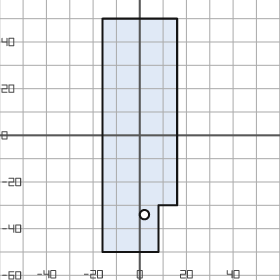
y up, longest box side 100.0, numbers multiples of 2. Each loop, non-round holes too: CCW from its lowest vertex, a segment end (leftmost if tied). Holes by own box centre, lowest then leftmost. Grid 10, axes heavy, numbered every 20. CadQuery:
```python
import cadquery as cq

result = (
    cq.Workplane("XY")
    .moveTo(-16.0, -50.0)
    .lineTo(8.0, -50.0)
    .lineTo(8.0, -30.0)
    .lineTo(16.0, -30.0)
    .lineTo(16.0, 50.0)
    .lineTo(-16.0, 50.0)
    .close()
    .moveTo(2.0, -34.0)
    .circle(2.0)
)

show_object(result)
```